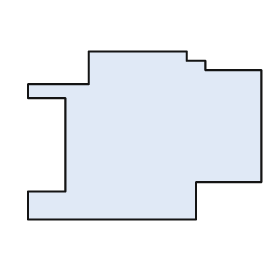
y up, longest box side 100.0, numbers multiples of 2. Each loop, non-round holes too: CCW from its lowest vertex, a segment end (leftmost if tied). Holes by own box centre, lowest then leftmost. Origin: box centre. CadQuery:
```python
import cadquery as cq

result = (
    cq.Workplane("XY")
    .moveTo(-50.0, -36.0)
    .lineTo(22.0, -36.0)
    .lineTo(22.0, -20.0)
    .lineTo(50.0, -20.0)
    .lineTo(50.0, 28.0)
    .lineTo(26.0, 28.0)
    .lineTo(26.0, 32.0)
    .lineTo(18.0, 32.0)
    .lineTo(18.0, 36.0)
    .lineTo(-24.0, 36.0)
    .lineTo(-24.0, 22.0)
    .lineTo(-50.0, 22.0)
    .lineTo(-50.0, 16.0)
    .lineTo(-34.0, 16.0)
    .lineTo(-34.0, -24.0)
    .lineTo(-50.0, -24.0)
    .close()
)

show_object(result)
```